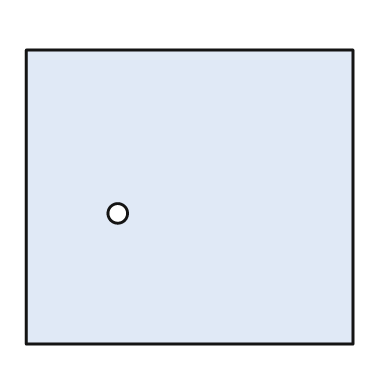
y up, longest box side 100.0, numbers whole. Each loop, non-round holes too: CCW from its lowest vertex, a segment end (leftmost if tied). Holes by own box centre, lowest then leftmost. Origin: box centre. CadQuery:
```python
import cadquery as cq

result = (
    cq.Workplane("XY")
    .moveTo(-50.0, -45.0)
    .lineTo(50.0, -45.0)
    .lineTo(50.0, 45.0)
    .lineTo(-50.0, 45.0)
    .close()
    .moveTo(-22.0, -5.0)
    .circle(3.0)
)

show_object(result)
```